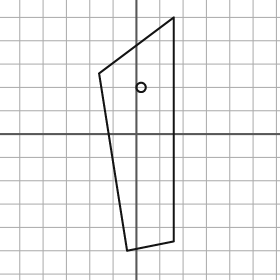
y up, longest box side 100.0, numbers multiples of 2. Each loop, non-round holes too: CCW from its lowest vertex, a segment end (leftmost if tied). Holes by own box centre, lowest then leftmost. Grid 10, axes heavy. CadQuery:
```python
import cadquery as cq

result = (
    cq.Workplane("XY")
    .moveTo(-4.0, -50.0)
    .lineTo(16.0, -46.0)
    .lineTo(16.0, 50.0)
    .lineTo(-16.0, 26.0)
    .close()
    .moveTo(2.0, 20.0)
    .circle(2.0)
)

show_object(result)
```